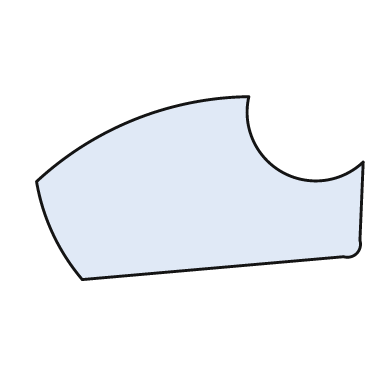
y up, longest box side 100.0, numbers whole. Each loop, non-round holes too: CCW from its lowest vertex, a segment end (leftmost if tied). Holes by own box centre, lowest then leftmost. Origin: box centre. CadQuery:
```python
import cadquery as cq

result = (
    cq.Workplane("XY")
    .moveTo(-36.0, -28.0)
    .lineTo(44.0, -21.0)
    .threePointArc((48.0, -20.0), (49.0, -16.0))
    .lineTo(50.0, 8.0)
    .threePointArc((25.0, 5.0), (15.0, 28.0))
    .threePointArc((-20.0, 21.0), (-50.0, 2.0))
    .threePointArc((-45.0, -14.0), (-36.0, -28.0))
    .close()
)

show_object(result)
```